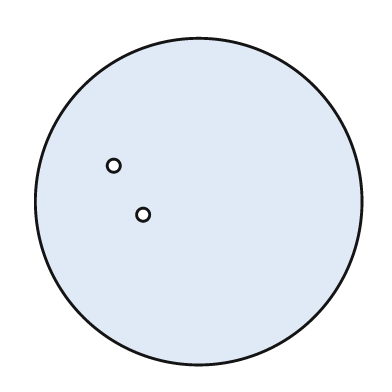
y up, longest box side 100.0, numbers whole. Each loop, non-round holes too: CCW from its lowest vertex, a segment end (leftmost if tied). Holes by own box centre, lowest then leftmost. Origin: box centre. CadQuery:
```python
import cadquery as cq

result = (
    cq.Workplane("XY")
    .moveTo(0.0, 0.0)
    .circle(50.0)
    .moveTo(-17.0, -4.0)
    .circle(2.0)
    .moveTo(-26.0, 11.0)
    .circle(2.0)
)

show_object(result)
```